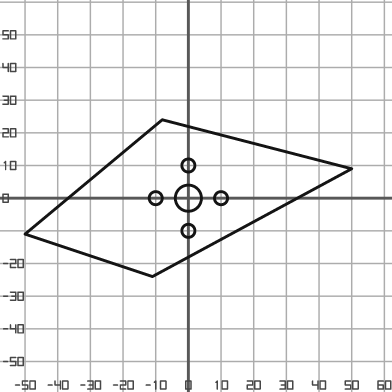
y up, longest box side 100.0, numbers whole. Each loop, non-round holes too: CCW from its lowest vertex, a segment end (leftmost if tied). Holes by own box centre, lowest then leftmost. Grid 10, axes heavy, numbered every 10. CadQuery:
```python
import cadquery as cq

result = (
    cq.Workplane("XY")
    .moveTo(-11.0, -24.0)
    .lineTo(50.0, 9.0)
    .lineTo(-8.0, 24.0)
    .lineTo(-50.0, -11.0)
    .close()
    .moveTo(0.0, -10.0)
    .circle(2.0)
    .moveTo(-10.0, 0.0)
    .circle(2.0)
    .moveTo(0.0, 0.0)
    .circle(4.0)
    .moveTo(10.0, 0.0)
    .circle(2.0)
    .moveTo(0.0, 10.0)
    .circle(2.0)
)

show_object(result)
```